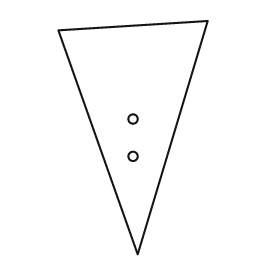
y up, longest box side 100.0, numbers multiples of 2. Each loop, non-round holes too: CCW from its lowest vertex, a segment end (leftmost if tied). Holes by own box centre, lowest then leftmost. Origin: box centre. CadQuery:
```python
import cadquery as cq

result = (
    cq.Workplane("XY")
    .moveTo(2.0, -50.0)
    .lineTo(32.0, 50.0)
    .lineTo(-32.0, 46.0)
    .close()
    .moveTo(0.0, -8.0)
    .circle(2.0)
    .moveTo(0.0, 8.0)
    .circle(2.0)
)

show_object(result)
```